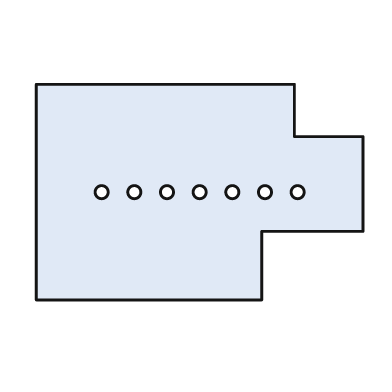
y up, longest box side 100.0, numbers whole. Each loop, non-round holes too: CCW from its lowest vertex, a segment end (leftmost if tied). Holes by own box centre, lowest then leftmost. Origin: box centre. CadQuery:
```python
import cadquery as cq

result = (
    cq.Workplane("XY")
    .moveTo(-50.0, -33.0)
    .lineTo(19.0, -33.0)
    .lineTo(19.0, -12.0)
    .lineTo(50.0, -12.0)
    .lineTo(50.0, 17.0)
    .lineTo(29.0, 17.0)
    .lineTo(29.0, 33.0)
    .lineTo(-50.0, 33.0)
    .close()
    .moveTo(-30.0, 0.0)
    .circle(2.0)
    .moveTo(-20.0, 0.0)
    .circle(2.0)
    .moveTo(-10.0, 0.0)
    .circle(2.0)
    .moveTo(0.0, 0.0)
    .circle(2.0)
    .moveTo(10.0, 0.0)
    .circle(2.0)
    .moveTo(20.0, 0.0)
    .circle(2.0)
    .moveTo(30.0, 0.0)
    .circle(2.0)
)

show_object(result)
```